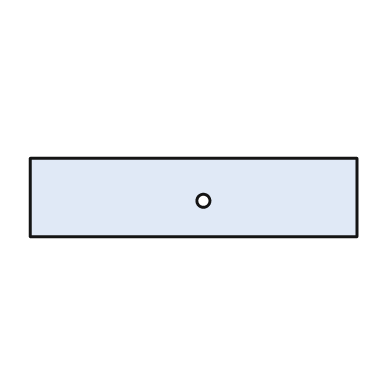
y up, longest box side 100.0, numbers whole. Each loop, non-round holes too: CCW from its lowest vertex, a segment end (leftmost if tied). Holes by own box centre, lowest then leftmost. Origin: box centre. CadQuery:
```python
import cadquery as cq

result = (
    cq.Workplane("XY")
    .moveTo(-50.0, -12.0)
    .lineTo(50.0, -12.0)
    .lineTo(50.0, 12.0)
    .lineTo(-50.0, 12.0)
    .close()
    .moveTo(3.0, -1.0)
    .circle(2.0)
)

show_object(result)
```